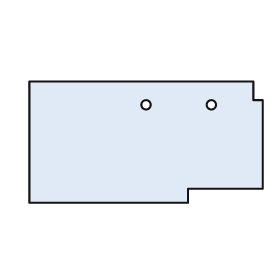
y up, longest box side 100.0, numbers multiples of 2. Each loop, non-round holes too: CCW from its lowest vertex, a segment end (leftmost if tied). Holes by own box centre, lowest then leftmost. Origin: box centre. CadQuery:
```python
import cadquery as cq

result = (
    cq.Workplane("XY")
    .moveTo(-50.0, -26.0)
    .lineTo(18.0, -26.0)
    .lineTo(18.0, -20.0)
    .lineTo(50.0, -20.0)
    .lineTo(50.0, 18.0)
    .lineTo(46.0, 18.0)
    .lineTo(46.0, 26.0)
    .lineTo(-50.0, 26.0)
    .close()
    .moveTo(0.0, 16.0)
    .circle(2.0)
    .moveTo(28.0, 16.0)
    .circle(2.0)
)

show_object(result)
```